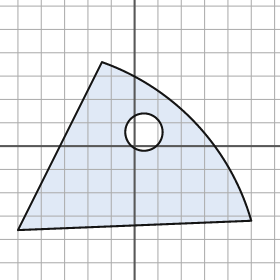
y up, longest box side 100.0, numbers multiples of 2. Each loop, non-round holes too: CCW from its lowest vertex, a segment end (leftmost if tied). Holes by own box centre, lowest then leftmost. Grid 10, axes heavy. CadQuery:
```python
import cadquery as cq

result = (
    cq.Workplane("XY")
    .moveTo(-50.0, -36.0)
    .lineTo(50.0, -32.0)
    .threePointArc((26.0, 10.0), (-14.0, 36.0))
    .close()
    .moveTo(4.0, 6.0)
    .circle(8.0)
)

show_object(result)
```